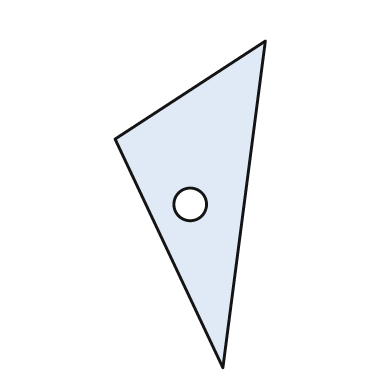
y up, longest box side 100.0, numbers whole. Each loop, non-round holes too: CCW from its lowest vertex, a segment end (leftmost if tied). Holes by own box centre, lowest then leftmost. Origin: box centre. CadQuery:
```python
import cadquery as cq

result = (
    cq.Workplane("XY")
    .moveTo(10.0, -50.0)
    .lineTo(23.0, 50.0)
    .lineTo(-23.0, 20.0)
    .close()
    .moveTo(0.0, 0.0)
    .circle(5.0)
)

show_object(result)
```